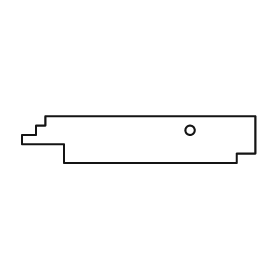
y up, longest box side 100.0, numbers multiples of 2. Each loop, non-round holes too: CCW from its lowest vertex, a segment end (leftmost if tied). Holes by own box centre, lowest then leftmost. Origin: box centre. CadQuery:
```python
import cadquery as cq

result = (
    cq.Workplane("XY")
    .moveTo(-32.0, -10.0)
    .lineTo(42.0, -10.0)
    .lineTo(42.0, -6.0)
    .lineTo(50.0, -6.0)
    .lineTo(50.0, 10.0)
    .lineTo(-40.0, 10.0)
    .lineTo(-40.0, 6.0)
    .lineTo(-44.0, 6.0)
    .lineTo(-44.0, 2.0)
    .lineTo(-50.0, 2.0)
    .lineTo(-50.0, -2.0)
    .lineTo(-32.0, -2.0)
    .close()
    .moveTo(22.0, 4.0)
    .circle(2.0)
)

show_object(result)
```